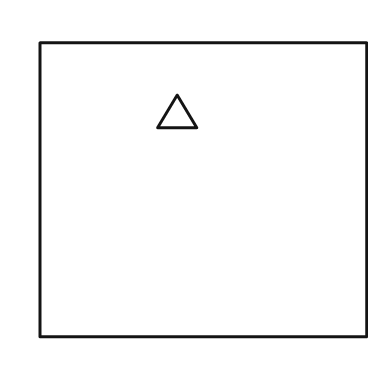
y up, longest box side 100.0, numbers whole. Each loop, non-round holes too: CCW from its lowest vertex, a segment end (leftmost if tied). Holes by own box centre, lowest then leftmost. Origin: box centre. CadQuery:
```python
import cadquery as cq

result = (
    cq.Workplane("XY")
    .moveTo(-50.0, -45.0)
    .lineTo(50.0, -45.0)
    .lineTo(50.0, 45.0)
    .lineTo(-50.0, 45.0)
    .close()
    .moveTo(-14.0, 19.0)
    .lineTo(-2.0, 19.0)
    .lineTo(-8.0, 29.0)
    .close()
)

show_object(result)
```